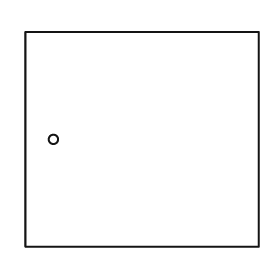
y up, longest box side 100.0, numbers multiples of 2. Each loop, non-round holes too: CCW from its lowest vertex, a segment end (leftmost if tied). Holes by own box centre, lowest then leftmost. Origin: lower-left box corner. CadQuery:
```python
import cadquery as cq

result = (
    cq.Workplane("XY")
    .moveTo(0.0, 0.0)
    .lineTo(100.0, 0.0)
    .lineTo(100.0, 92.0)
    .lineTo(0.0, 92.0)
    .close()
    .moveTo(12.0, 46.0)
    .circle(2.0)
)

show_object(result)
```